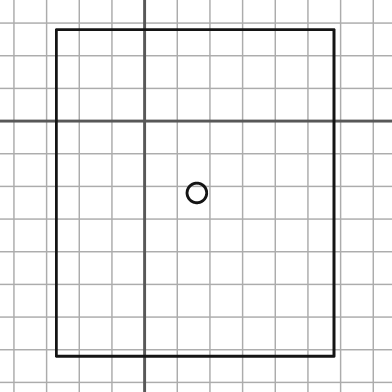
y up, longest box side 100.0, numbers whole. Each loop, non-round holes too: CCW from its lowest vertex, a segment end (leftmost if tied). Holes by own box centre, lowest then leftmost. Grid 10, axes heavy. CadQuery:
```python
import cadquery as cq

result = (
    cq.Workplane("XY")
    .moveTo(-27.0, -72.0)
    .lineTo(58.0, -72.0)
    .lineTo(58.0, 28.0)
    .lineTo(-27.0, 28.0)
    .close()
    .moveTo(16.0, -22.0)
    .circle(3.0)
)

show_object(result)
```